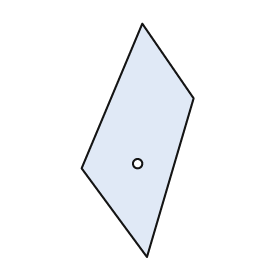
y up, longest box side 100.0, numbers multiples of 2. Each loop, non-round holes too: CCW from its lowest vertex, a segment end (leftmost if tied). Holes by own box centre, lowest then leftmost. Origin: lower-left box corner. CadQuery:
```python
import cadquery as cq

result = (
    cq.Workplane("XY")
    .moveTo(28.0, 0.0)
    .lineTo(48.0, 68.0)
    .lineTo(26.0, 100.0)
    .lineTo(0.0, 38.0)
    .close()
    .moveTo(24.0, 40.0)
    .circle(2.0)
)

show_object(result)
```